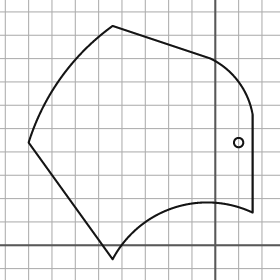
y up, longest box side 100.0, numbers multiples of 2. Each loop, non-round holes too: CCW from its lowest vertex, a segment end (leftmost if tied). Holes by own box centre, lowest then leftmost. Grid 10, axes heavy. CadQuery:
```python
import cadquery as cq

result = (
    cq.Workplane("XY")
    .moveTo(-44.0, -6.0)
    .threePointArc((-18.0, 16.0), (16.0, 14.0))
    .lineTo(16.0, 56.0)
    .threePointArc((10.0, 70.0), (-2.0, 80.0))
    .lineTo(-44.0, 94.0)
    .threePointArc((-66.0, 72.0), (-80.0, 44.0))
    .close()
    .moveTo(10.0, 44.0)
    .circle(2.0)
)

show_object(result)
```